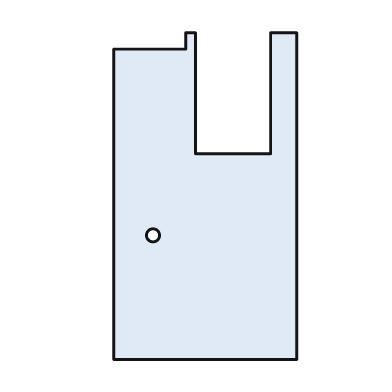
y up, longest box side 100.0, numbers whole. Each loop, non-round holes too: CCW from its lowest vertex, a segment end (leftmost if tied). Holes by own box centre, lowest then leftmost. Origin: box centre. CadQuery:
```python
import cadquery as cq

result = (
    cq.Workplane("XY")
    .moveTo(-28.0, -50.0)
    .lineTo(28.0, -50.0)
    .lineTo(28.0, 50.0)
    .lineTo(20.0, 50.0)
    .lineTo(20.0, 13.0)
    .lineTo(-3.0, 13.0)
    .lineTo(-3.0, 50.0)
    .lineTo(-6.0, 50.0)
    .lineTo(-6.0, 45.0)
    .lineTo(-28.0, 45.0)
    .close()
    .moveTo(-16.0, -12.0)
    .circle(2.0)
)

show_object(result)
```